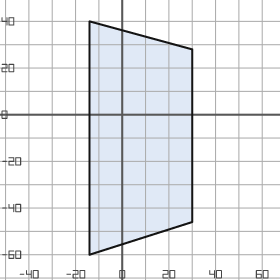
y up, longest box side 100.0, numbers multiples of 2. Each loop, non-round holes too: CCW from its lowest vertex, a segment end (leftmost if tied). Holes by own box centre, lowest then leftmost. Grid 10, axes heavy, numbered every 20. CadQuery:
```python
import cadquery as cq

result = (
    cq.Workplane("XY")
    .moveTo(-14.0, -60.0)
    .lineTo(30.0, -46.0)
    .lineTo(30.0, 28.0)
    .lineTo(-14.0, 40.0)
    .close()
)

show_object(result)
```